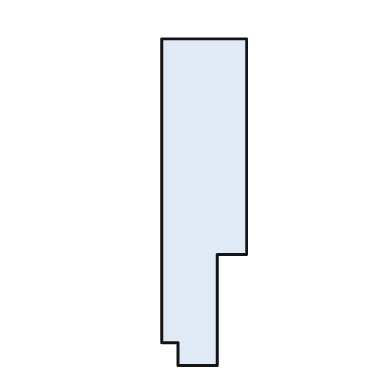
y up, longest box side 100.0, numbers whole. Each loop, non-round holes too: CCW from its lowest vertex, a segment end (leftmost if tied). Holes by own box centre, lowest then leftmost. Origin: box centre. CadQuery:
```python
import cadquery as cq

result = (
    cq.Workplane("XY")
    .moveTo(-8.0, -50.0)
    .lineTo(4.0, -50.0)
    .lineTo(4.0, -16.0)
    .lineTo(13.0, -16.0)
    .lineTo(13.0, 50.0)
    .lineTo(-13.0, 50.0)
    .lineTo(-13.0, -43.0)
    .lineTo(-8.0, -43.0)
    .close()
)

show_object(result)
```